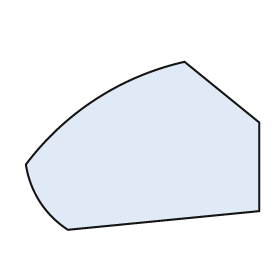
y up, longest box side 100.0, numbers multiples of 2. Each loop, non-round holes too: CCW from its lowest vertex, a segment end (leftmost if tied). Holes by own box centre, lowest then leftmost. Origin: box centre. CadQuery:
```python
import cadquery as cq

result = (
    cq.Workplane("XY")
    .moveTo(-32.0, -36.0)
    .lineTo(50.0, -28.0)
    .lineTo(50.0, 10.0)
    .lineTo(18.0, 36.0)
    .threePointArc((-20.0, 20.0), (-50.0, -8.0))
    .threePointArc((-44.0, -24.0), (-32.0, -36.0))
    .close()
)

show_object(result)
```